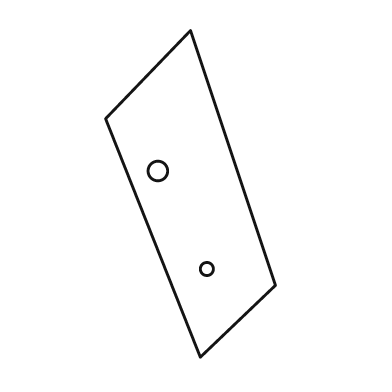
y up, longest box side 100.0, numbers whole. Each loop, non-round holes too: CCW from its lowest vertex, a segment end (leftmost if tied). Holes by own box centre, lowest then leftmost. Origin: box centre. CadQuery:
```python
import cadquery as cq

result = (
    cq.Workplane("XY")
    .moveTo(3.0, -50.0)
    .lineTo(26.0, -28.0)
    .lineTo(0.0, 50.0)
    .lineTo(-26.0, 23.0)
    .close()
    .moveTo(5.0, -23.0)
    .circle(2.0)
    .moveTo(-10.0, 7.0)
    .circle(3.0)
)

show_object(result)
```